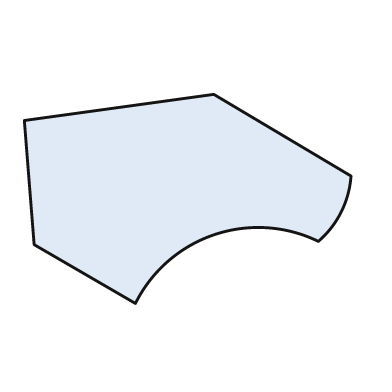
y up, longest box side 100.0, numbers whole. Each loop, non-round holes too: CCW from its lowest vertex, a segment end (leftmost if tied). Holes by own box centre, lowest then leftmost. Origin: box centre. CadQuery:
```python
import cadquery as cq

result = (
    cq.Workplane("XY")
    .moveTo(-16.0, -32.0)
    .threePointArc((8.0, -11.0), (40.0, -13.0))
    .threePointArc((47.0, -4.0), (50.0, 7.0))
    .lineTo(8.0, 32.0)
    .lineTo(-50.0, 24.0)
    .lineTo(-47.0, -14.0)
    .close()
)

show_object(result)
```